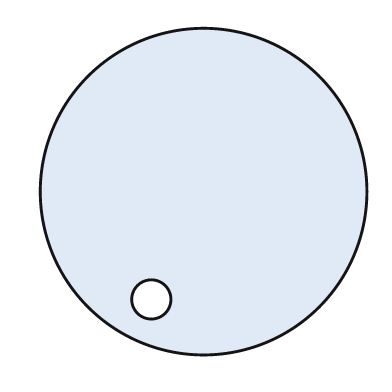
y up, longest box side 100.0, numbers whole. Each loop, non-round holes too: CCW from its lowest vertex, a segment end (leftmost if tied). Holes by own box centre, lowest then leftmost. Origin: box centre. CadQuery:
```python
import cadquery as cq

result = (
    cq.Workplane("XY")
    .moveTo(0.0, 0.0)
    .circle(50.0)
    .moveTo(-16.0, -33.0)
    .circle(6.0)
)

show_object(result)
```